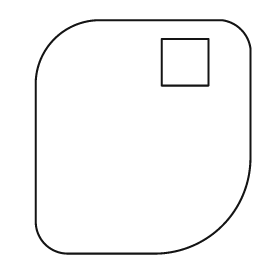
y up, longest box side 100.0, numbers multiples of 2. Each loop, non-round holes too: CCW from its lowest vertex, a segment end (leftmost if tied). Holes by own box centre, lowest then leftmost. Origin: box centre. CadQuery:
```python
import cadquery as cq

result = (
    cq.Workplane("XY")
    .moveTo(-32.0, -50.0)
    .lineTo(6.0, -50.0)
    .threePointArc((34.0, -38.0), (46.0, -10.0))
    .lineTo(46.0, 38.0)
    .threePointArc((42.0, 46.0), (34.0, 50.0))
    .lineTo(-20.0, 50.0)
    .threePointArc((-38.0, 42.0), (-46.0, 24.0))
    .lineTo(-46.0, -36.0)
    .threePointArc((-42.0, -46.0), (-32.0, -50.0))
    .close()
    .moveTo(8.0, 22.0)
    .lineTo(28.0, 22.0)
    .lineTo(28.0, 42.0)
    .lineTo(8.0, 42.0)
    .close()
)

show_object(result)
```